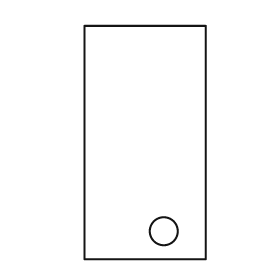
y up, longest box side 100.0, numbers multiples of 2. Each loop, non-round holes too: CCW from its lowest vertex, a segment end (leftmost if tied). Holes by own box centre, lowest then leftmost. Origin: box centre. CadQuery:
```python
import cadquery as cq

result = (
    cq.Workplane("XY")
    .moveTo(-26.0, -50.0)
    .lineTo(26.0, -50.0)
    .lineTo(26.0, 50.0)
    .lineTo(-26.0, 50.0)
    .close()
    .moveTo(8.0, -38.0)
    .circle(6.0)
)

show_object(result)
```